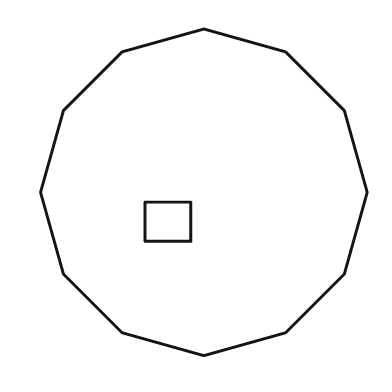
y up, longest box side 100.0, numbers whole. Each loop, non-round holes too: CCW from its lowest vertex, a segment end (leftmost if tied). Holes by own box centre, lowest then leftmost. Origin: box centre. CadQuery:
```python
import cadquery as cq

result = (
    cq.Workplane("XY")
    .moveTo(0.0, -50.0)
    .lineTo(25.0, -43.0)
    .lineTo(43.0, -25.0)
    .lineTo(50.0, 0.0)
    .lineTo(43.0, 25.0)
    .lineTo(25.0, 43.0)
    .lineTo(0.0, 50.0)
    .lineTo(-25.0, 43.0)
    .lineTo(-43.0, 25.0)
    .lineTo(-50.0, 0.0)
    .lineTo(-43.0, -25.0)
    .lineTo(-25.0, -43.0)
    .close()
    .moveTo(-18.0, -15.0)
    .lineTo(-4.0, -15.0)
    .lineTo(-4.0, -3.0)
    .lineTo(-18.0, -3.0)
    .close()
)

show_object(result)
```